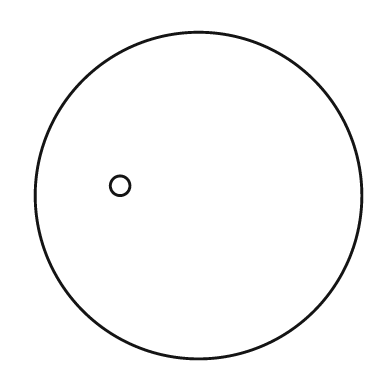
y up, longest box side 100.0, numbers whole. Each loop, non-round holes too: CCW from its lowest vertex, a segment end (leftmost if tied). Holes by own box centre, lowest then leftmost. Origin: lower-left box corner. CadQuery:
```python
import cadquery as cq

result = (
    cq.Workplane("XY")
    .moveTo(50.0, 50.0)
    .circle(50.0)
    .moveTo(26.0, 53.0)
    .circle(3.0)
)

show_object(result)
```